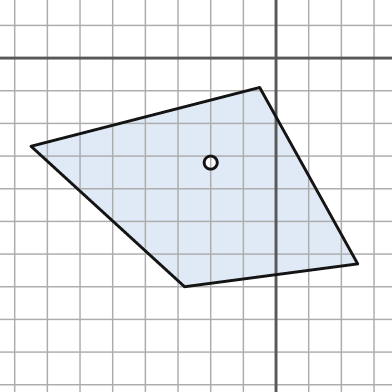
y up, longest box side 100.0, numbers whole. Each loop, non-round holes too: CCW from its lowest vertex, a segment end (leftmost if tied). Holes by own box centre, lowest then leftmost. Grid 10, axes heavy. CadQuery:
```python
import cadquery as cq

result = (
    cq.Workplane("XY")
    .moveTo(-28.0, -70.0)
    .lineTo(25.0, -63.0)
    .lineTo(-5.0, -9.0)
    .lineTo(-75.0, -27.0)
    .close()
    .moveTo(-20.0, -32.0)
    .circle(2.0)
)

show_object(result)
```